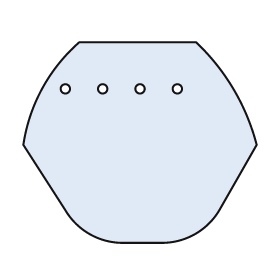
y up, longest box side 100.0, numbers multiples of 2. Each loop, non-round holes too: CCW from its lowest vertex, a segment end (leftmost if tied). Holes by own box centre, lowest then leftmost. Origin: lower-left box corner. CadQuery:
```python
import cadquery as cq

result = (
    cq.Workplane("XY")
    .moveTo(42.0, 0.0)
    .lineTo(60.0, 0.0)
    .threePointArc((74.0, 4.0), (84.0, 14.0))
    .lineTo(100.0, 42.0)
    .threePointArc((90.0, 66.0), (74.0, 86.0))
    .lineTo(24.0, 86.0)
    .threePointArc((8.0, 66.0), (0.0, 42.0))
    .lineTo(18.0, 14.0)
    .threePointArc((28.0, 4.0), (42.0, 0.0))
    .close()
    .moveTo(18.0, 66.0)
    .circle(2.0)
    .moveTo(34.0, 66.0)
    .circle(2.0)
    .moveTo(50.0, 66.0)
    .circle(2.0)
    .moveTo(66.0, 66.0)
    .circle(2.0)
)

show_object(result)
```